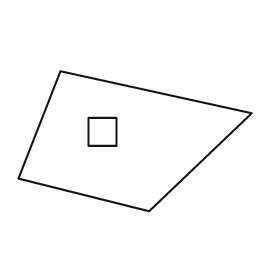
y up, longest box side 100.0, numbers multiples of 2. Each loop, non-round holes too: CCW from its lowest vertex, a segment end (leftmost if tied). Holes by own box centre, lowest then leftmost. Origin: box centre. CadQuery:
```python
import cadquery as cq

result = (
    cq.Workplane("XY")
    .moveTo(6.0, -30.0)
    .lineTo(50.0, 12.0)
    .lineTo(-32.0, 30.0)
    .lineTo(-50.0, -16.0)
    .close()
    .moveTo(-20.0, -2.0)
    .lineTo(-8.0, -2.0)
    .lineTo(-8.0, 10.0)
    .lineTo(-20.0, 10.0)
    .close()
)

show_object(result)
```